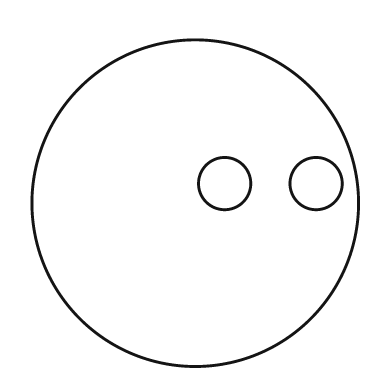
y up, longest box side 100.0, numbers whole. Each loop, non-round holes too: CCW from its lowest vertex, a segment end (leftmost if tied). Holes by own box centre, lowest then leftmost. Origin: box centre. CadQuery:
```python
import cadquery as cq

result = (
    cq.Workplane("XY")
    .moveTo(0.0, 0.0)
    .circle(50.0)
    .moveTo(9.0, 6.0)
    .circle(8.0)
    .moveTo(37.0, 6.0)
    .circle(8.0)
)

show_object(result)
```